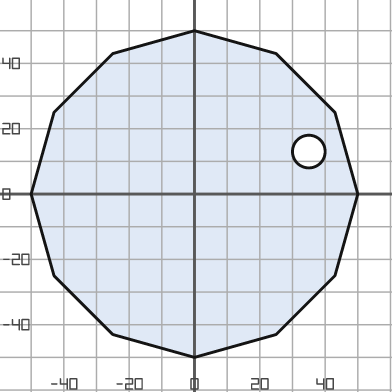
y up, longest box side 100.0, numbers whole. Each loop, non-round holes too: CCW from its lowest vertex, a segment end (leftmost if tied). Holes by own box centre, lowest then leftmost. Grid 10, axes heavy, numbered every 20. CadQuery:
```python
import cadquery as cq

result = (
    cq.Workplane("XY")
    .moveTo(0.0, -50.0)
    .lineTo(25.0, -43.0)
    .lineTo(43.0, -25.0)
    .lineTo(50.0, 0.0)
    .lineTo(43.0, 25.0)
    .lineTo(25.0, 43.0)
    .lineTo(0.0, 50.0)
    .lineTo(-25.0, 43.0)
    .lineTo(-43.0, 25.0)
    .lineTo(-50.0, 0.0)
    .lineTo(-43.0, -25.0)
    .lineTo(-25.0, -43.0)
    .close()
    .moveTo(35.0, 13.0)
    .circle(5.0)
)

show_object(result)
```